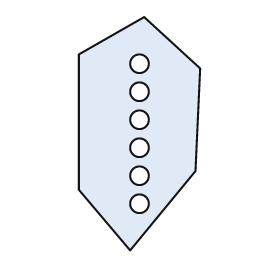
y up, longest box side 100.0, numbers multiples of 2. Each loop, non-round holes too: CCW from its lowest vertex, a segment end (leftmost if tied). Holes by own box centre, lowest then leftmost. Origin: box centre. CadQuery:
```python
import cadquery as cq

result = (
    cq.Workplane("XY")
    .moveTo(-4.0, -50.0)
    .lineTo(24.0, -16.0)
    .lineTo(26.0, 28.0)
    .lineTo(2.0, 50.0)
    .lineTo(-26.0, 34.0)
    .lineTo(-26.0, -24.0)
    .close()
    .moveTo(0.0, -30.0)
    .circle(4.0)
    .moveTo(0.0, -18.0)
    .circle(4.0)
    .moveTo(0.0, -6.0)
    .circle(4.0)
    .moveTo(0.0, 6.0)
    .circle(4.0)
    .moveTo(0.0, 18.0)
    .circle(4.0)
    .moveTo(0.0, 30.0)
    .circle(4.0)
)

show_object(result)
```